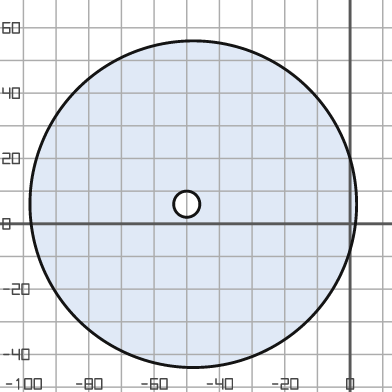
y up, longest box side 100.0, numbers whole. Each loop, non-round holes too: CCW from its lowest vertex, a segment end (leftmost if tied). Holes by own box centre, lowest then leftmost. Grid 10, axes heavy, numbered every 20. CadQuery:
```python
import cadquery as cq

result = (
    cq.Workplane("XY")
    .moveTo(-48.0, 6.0)
    .circle(50.0)
    .moveTo(-50.0, 6.0)
    .circle(4.0)
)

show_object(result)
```